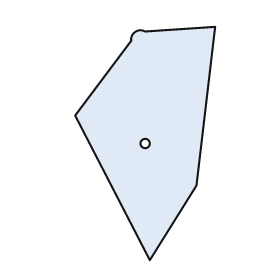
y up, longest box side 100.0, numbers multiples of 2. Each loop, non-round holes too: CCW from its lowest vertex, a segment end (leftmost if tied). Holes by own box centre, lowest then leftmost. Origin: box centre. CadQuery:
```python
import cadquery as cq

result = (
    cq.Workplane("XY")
    .moveTo(2.0, -50.0)
    .lineTo(22.0, -18.0)
    .lineTo(30.0, 50.0)
    .lineTo(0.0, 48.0)
    .threePointArc((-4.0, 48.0), (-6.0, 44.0))
    .lineTo(-30.0, 12.0)
    .close()
    .moveTo(0.0, 0.0)
    .circle(2.0)
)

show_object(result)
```